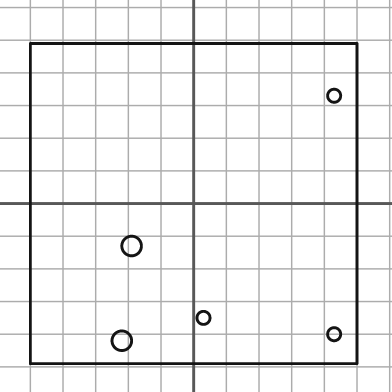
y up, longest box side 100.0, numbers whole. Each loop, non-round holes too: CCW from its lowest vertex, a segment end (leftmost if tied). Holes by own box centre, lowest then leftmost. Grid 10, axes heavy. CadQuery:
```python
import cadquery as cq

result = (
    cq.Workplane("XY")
    .moveTo(-50.0, -49.0)
    .lineTo(50.0, -49.0)
    .lineTo(50.0, 49.0)
    .lineTo(-50.0, 49.0)
    .close()
    .moveTo(-22.0, -42.0)
    .circle(3.0)
    .moveTo(43.0, -40.0)
    .circle(2.0)
    .moveTo(3.0, -35.0)
    .circle(2.0)
    .moveTo(-19.0, -13.0)
    .circle(3.0)
    .moveTo(43.0, 33.0)
    .circle(2.0)
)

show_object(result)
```